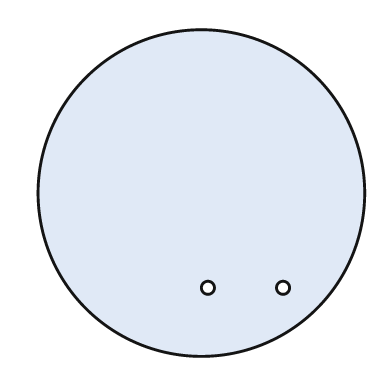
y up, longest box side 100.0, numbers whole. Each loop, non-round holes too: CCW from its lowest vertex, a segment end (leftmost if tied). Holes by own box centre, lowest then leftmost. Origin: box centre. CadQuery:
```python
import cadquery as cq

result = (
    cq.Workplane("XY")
    .moveTo(0.0, 0.0)
    .circle(50.0)
    .moveTo(2.0, -29.0)
    .circle(2.0)
    .moveTo(25.0, -29.0)
    .circle(2.0)
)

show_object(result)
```